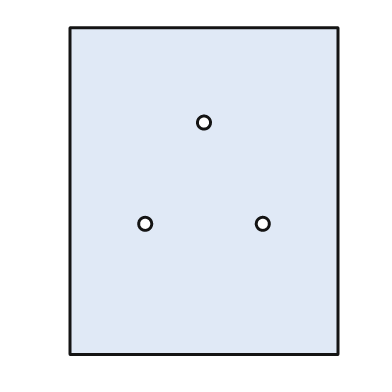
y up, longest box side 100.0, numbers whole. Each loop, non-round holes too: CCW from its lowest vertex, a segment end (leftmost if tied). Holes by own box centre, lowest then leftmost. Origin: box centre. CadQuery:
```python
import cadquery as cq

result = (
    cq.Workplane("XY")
    .moveTo(-41.0, -50.0)
    .lineTo(41.0, -50.0)
    .lineTo(41.0, 50.0)
    .lineTo(-41.0, 50.0)
    .close()
    .moveTo(-18.0, -10.0)
    .circle(2.0)
    .moveTo(18.0, -10.0)
    .circle(2.0)
    .moveTo(0.0, 21.0)
    .circle(2.0)
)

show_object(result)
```